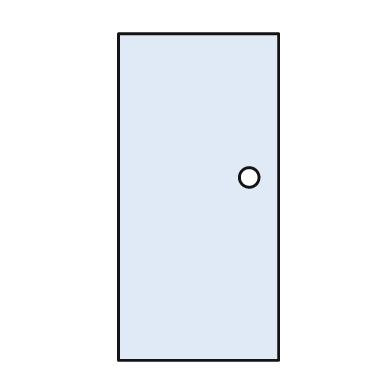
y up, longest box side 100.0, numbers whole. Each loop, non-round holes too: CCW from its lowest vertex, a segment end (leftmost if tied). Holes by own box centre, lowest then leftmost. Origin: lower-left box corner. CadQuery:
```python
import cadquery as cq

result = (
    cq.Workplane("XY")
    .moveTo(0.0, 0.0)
    .lineTo(49.0, 0.0)
    .lineTo(49.0, 100.0)
    .lineTo(0.0, 100.0)
    .close()
    .moveTo(40.0, 56.0)
    .circle(3.0)
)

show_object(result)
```